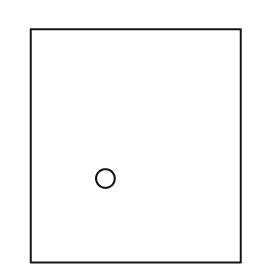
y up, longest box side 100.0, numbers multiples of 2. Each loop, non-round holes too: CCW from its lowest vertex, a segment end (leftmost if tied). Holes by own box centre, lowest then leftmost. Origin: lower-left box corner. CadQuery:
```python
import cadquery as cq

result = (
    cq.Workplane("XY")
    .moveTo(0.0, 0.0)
    .lineTo(90.0, 0.0)
    .lineTo(90.0, 100.0)
    .lineTo(0.0, 100.0)
    .close()
    .moveTo(32.0, 36.0)
    .circle(4.0)
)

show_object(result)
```